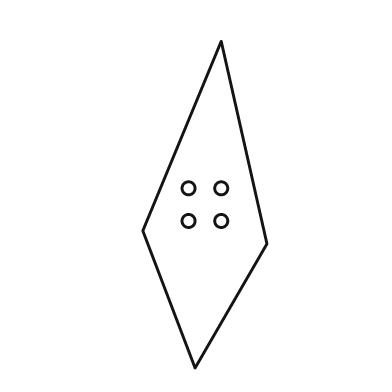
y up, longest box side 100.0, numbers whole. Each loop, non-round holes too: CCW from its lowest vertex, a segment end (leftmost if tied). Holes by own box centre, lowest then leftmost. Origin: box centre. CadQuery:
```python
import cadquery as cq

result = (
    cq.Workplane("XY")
    .moveTo(-3.0, -50.0)
    .lineTo(19.0, -12.0)
    .lineTo(5.0, 50.0)
    .lineTo(-19.0, -8.0)
    .close()
    .moveTo(-5.0, -5.0)
    .circle(2.0)
    .moveTo(5.0, -5.0)
    .circle(2.0)
    .moveTo(-5.0, 5.0)
    .circle(2.0)
    .moveTo(5.0, 5.0)
    .circle(2.0)
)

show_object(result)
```